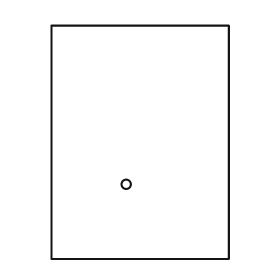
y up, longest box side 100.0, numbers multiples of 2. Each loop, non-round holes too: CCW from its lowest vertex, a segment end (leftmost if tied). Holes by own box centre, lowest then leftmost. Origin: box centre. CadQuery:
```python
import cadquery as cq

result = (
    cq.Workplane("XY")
    .moveTo(-38.0, -50.0)
    .lineTo(38.0, -50.0)
    .lineTo(38.0, 50.0)
    .lineTo(-38.0, 50.0)
    .close()
    .moveTo(-6.0, -18.0)
    .circle(2.0)
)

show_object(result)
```